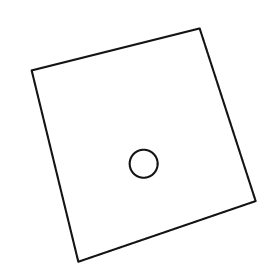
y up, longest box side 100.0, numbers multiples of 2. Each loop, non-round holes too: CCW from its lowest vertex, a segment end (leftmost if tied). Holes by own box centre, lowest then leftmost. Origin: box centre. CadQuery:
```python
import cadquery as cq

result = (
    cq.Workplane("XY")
    .moveTo(-28.0, -50.0)
    .lineTo(48.0, -24.0)
    .lineTo(24.0, 50.0)
    .lineTo(-48.0, 32.0)
    .close()
    .moveTo(0.0, -8.0)
    .circle(6.0)
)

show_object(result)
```